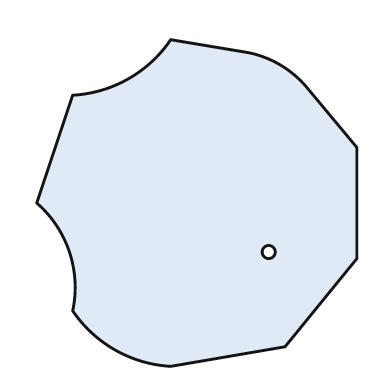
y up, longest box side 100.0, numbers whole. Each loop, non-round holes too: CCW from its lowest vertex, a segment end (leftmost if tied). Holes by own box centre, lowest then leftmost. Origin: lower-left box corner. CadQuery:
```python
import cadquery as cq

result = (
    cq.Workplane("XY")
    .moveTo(41.0, 0.0)
    .lineTo(76.0, 6.0)
    .lineTo(98.0, 33.0)
    .lineTo(98.0, 67.0)
    .lineTo(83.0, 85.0)
    .threePointArc((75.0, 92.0), (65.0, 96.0))
    .lineTo(41.0, 100.0)
    .threePointArc((28.0, 88.0), (11.0, 83.0))
    .lineTo(0.0, 50.0)
    .threePointArc((10.0, 35.0), (11.0, 17.0))
    .threePointArc((24.0, 5.0), (41.0, 0.0))
    .close()
    .moveTo(71.0, 35.0)
    .circle(2.0)
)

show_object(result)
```